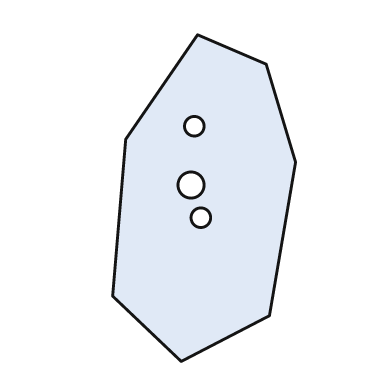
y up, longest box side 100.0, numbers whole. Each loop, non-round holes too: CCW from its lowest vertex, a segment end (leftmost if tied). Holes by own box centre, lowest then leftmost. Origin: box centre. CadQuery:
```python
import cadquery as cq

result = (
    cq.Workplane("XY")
    .moveTo(-7.0, -50.0)
    .lineTo(20.0, -36.0)
    .lineTo(28.0, 11.0)
    .lineTo(19.0, 41.0)
    .lineTo(-2.0, 50.0)
    .lineTo(-24.0, 18.0)
    .lineTo(-28.0, -30.0)
    .close()
    .moveTo(-1.0, -6.0)
    .circle(3.0)
    .moveTo(-4.0, 4.0)
    .circle(4.0)
    .moveTo(-3.0, 22.0)
    .circle(3.0)
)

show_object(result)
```